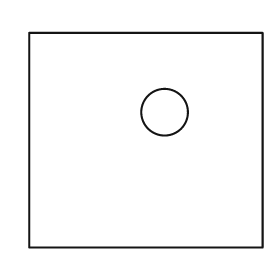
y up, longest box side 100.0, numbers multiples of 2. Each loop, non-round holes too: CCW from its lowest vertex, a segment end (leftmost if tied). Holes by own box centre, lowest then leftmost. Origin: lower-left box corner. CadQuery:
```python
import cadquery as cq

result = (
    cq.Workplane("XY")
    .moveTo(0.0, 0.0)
    .lineTo(100.0, 0.0)
    .lineTo(100.0, 92.0)
    .lineTo(0.0, 92.0)
    .close()
    .moveTo(58.0, 58.0)
    .circle(10.0)
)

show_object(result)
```